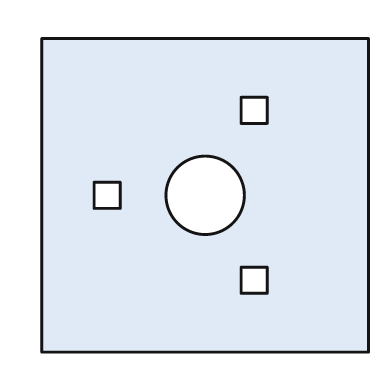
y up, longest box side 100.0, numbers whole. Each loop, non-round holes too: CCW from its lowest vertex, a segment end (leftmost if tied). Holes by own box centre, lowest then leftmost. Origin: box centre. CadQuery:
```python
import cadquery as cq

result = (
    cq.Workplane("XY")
    .moveTo(-50.0, -48.0)
    .lineTo(50.0, -48.0)
    .lineTo(50.0, 48.0)
    .lineTo(-50.0, 48.0)
    .close()
    .moveTo(11.0, -30.0)
    .lineTo(19.0, -30.0)
    .lineTo(19.0, -22.0)
    .lineTo(11.0, -22.0)
    .close()
    .moveTo(-34.0, -4.0)
    .lineTo(-26.0, -4.0)
    .lineTo(-26.0, 4.0)
    .lineTo(-34.0, 4.0)
    .close()
    .moveTo(0.0, 0.0)
    .circle(12.0)
    .moveTo(11.0, 22.0)
    .lineTo(19.0, 22.0)
    .lineTo(19.0, 30.0)
    .lineTo(11.0, 30.0)
    .close()
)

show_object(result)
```